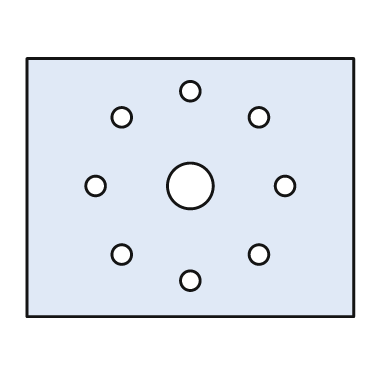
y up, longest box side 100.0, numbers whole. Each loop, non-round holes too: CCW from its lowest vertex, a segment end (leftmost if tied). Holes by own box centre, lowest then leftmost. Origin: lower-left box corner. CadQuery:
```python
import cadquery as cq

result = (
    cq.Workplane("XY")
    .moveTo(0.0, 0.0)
    .lineTo(100.0, 0.0)
    .lineTo(100.0, 79.0)
    .lineTo(0.0, 79.0)
    .close()
    .moveTo(50.0, 11.0)
    .circle(3.0)
    .moveTo(29.0, 19.0)
    .circle(3.0)
    .moveTo(71.0, 19.0)
    .circle(3.0)
    .moveTo(21.0, 40.0)
    .circle(3.0)
    .moveTo(50.0, 40.0)
    .circle(7.0)
    .moveTo(79.0, 40.0)
    .circle(3.0)
    .moveTo(29.0, 61.0)
    .circle(3.0)
    .moveTo(71.0, 61.0)
    .circle(3.0)
    .moveTo(50.0, 69.0)
    .circle(3.0)
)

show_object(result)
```